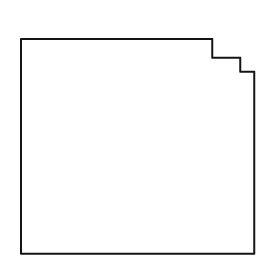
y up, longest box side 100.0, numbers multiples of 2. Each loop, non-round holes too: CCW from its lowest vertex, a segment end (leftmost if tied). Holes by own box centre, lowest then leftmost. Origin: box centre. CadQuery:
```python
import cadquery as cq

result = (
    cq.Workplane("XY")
    .moveTo(-50.0, -46.0)
    .lineTo(50.0, -46.0)
    .lineTo(50.0, 32.0)
    .lineTo(44.0, 32.0)
    .lineTo(44.0, 38.0)
    .lineTo(32.0, 38.0)
    .lineTo(32.0, 46.0)
    .lineTo(-50.0, 46.0)
    .close()
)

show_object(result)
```